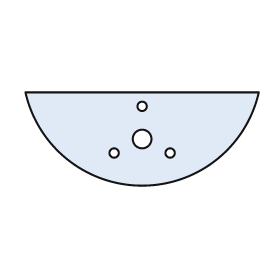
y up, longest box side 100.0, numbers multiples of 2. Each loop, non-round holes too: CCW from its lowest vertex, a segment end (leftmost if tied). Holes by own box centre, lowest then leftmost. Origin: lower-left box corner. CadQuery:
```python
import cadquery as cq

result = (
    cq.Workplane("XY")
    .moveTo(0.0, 40.0)
    .threePointArc((50.0, 0.0), (100.0, 40.0))
    .close()
    .moveTo(38.0, 14.0)
    .circle(2.0)
    .moveTo(62.0, 14.0)
    .circle(2.0)
    .moveTo(50.0, 20.0)
    .circle(4.0)
    .moveTo(50.0, 34.0)
    .circle(2.0)
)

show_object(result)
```